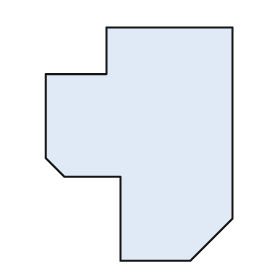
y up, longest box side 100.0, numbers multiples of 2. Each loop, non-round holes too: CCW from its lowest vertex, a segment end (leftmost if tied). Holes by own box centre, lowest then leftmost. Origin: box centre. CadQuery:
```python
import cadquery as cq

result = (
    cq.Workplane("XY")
    .moveTo(-8.0, -50.0)
    .lineTo(22.0, -50.0)
    .lineTo(40.0, -32.0)
    .lineTo(40.0, 50.0)
    .lineTo(-14.0, 50.0)
    .lineTo(-14.0, 30.0)
    .lineTo(-40.0, 30.0)
    .lineTo(-40.0, -6.0)
    .lineTo(-32.0, -14.0)
    .lineTo(-8.0, -14.0)
    .close()
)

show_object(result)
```